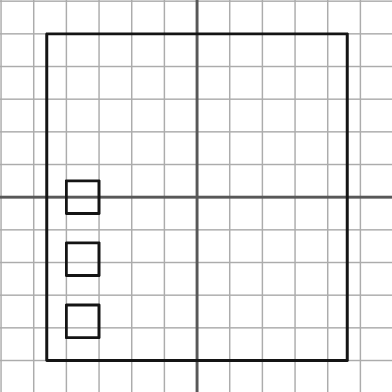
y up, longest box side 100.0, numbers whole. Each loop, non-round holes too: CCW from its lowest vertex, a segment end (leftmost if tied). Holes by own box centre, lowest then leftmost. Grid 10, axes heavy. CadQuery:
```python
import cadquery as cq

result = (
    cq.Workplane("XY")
    .moveTo(-46.0, -50.0)
    .lineTo(46.0, -50.0)
    .lineTo(46.0, 50.0)
    .lineTo(-46.0, 50.0)
    .close()
    .moveTo(-40.0, -43.0)
    .lineTo(-30.0, -43.0)
    .lineTo(-30.0, -33.0)
    .lineTo(-40.0, -33.0)
    .close()
    .moveTo(-40.0, -24.0)
    .lineTo(-30.0, -24.0)
    .lineTo(-30.0, -14.0)
    .lineTo(-40.0, -14.0)
    .close()
    .moveTo(-40.0, -5.0)
    .lineTo(-30.0, -5.0)
    .lineTo(-30.0, 5.0)
    .lineTo(-40.0, 5.0)
    .close()
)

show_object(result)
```